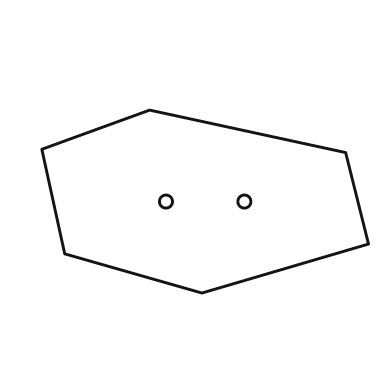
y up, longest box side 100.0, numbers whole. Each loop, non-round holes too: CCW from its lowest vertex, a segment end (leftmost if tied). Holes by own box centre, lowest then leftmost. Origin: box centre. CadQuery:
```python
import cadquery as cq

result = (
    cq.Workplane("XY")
    .moveTo(-1.0, -28.0)
    .lineTo(50.0, -13.0)
    .lineTo(43.0, 15.0)
    .lineTo(-17.0, 28.0)
    .lineTo(-50.0, 16.0)
    .lineTo(-43.0, -16.0)
    .close()
    .moveTo(-12.0, 0.0)
    .circle(2.0)
    .moveTo(12.0, 0.0)
    .circle(2.0)
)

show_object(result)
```